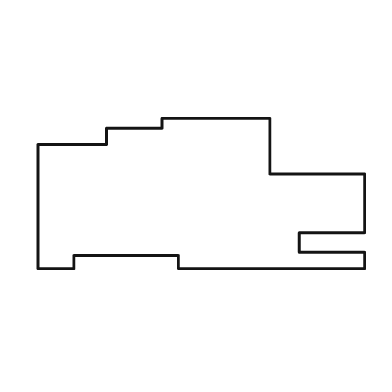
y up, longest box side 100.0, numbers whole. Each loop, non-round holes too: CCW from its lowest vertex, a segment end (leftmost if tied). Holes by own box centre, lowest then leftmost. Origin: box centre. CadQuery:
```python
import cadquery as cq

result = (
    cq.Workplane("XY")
    .moveTo(-50.0, -23.0)
    .lineTo(-39.0, -23.0)
    .lineTo(-39.0, -19.0)
    .lineTo(-7.0, -19.0)
    .lineTo(-7.0, -23.0)
    .lineTo(50.0, -23.0)
    .lineTo(50.0, -18.0)
    .lineTo(30.0, -18.0)
    .lineTo(30.0, -12.0)
    .lineTo(50.0, -12.0)
    .lineTo(50.0, 6.0)
    .lineTo(21.0, 6.0)
    .lineTo(21.0, 23.0)
    .lineTo(-12.0, 23.0)
    .lineTo(-12.0, 20.0)
    .lineTo(-29.0, 20.0)
    .lineTo(-29.0, 15.0)
    .lineTo(-50.0, 15.0)
    .close()
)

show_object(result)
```